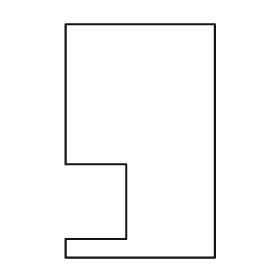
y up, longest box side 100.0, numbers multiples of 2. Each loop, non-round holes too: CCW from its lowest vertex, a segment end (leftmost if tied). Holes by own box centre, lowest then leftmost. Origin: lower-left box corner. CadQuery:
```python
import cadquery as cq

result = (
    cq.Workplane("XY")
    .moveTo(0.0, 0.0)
    .lineTo(64.0, 0.0)
    .lineTo(64.0, 100.0)
    .lineTo(0.0, 100.0)
    .lineTo(0.0, 40.0)
    .lineTo(26.0, 40.0)
    .lineTo(26.0, 8.0)
    .lineTo(0.0, 8.0)
    .close()
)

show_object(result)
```